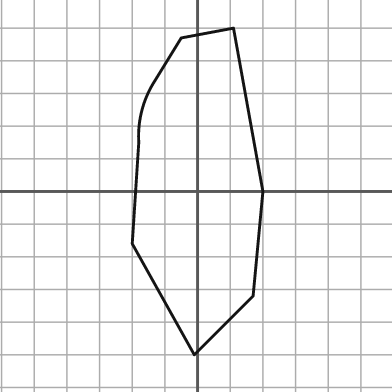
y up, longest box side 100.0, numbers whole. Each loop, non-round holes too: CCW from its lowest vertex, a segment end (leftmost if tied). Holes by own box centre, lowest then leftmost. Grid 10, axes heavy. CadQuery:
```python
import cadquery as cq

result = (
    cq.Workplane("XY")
    .moveTo(-1.0, -50.0)
    .lineTo(17.0, -32.0)
    .lineTo(20.0, 0.0)
    .lineTo(11.0, 50.0)
    .lineTo(-5.0, 47.0)
    .lineTo(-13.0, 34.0)
    .threePointArc((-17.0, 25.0), (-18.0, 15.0))
    .lineTo(-20.0, -16.0)
    .close()
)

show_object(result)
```